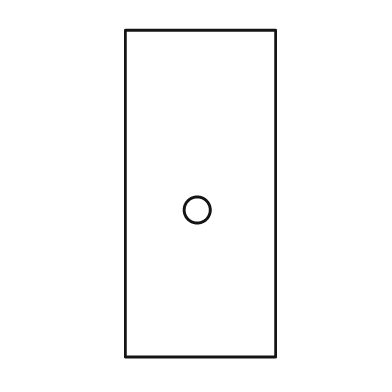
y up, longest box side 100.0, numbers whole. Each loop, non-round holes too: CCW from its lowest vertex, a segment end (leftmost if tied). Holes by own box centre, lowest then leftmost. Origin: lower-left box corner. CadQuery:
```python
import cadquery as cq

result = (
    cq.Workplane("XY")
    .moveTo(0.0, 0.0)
    .lineTo(46.0, 0.0)
    .lineTo(46.0, 100.0)
    .lineTo(0.0, 100.0)
    .close()
    .moveTo(22.0, 45.0)
    .circle(4.0)
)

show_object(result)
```